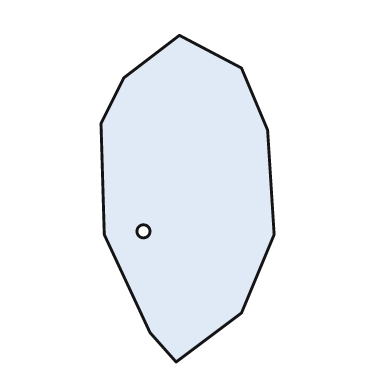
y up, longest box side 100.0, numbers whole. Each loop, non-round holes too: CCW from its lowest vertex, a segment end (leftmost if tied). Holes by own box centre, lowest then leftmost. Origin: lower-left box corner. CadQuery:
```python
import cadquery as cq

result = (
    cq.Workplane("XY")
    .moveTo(23.0, 0.0)
    .lineTo(43.0, 15.0)
    .lineTo(53.0, 39.0)
    .lineTo(51.0, 71.0)
    .lineTo(43.0, 90.0)
    .lineTo(24.0, 100.0)
    .lineTo(7.0, 87.0)
    .lineTo(0.0, 73.0)
    .lineTo(1.0, 39.0)
    .lineTo(15.0, 9.0)
    .close()
    .moveTo(13.0, 40.0)
    .circle(2.0)
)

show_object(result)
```